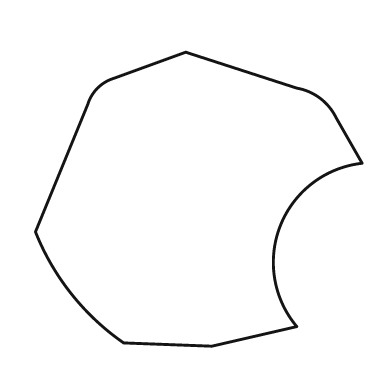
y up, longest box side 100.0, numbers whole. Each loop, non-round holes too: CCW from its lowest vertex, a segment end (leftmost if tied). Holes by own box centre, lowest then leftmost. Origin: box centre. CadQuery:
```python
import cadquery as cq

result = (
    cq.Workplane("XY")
    .moveTo(4.0, -45.0)
    .lineTo(30.0, -39.0)
    .threePointArc((25.0, -8.0), (50.0, 11.0))
    .lineTo(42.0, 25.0)
    .threePointArc((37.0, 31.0), (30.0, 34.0))
    .lineTo(-4.0, 45.0)
    .lineTo(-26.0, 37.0)
    .threePointArc((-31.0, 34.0), (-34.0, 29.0))
    .lineTo(-50.0, -10.0)
    .threePointArc((-39.0, -29.0), (-23.0, -44.0))
    .close()
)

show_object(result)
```